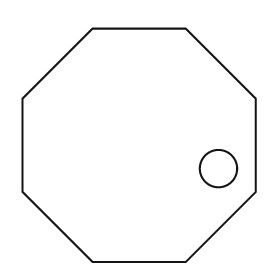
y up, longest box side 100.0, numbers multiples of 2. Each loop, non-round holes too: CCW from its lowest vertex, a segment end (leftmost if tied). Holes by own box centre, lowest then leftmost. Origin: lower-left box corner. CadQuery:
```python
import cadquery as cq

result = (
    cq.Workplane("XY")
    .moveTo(30.0, 0.0)
    .lineTo(70.0, 0.0)
    .lineTo(100.0, 30.0)
    .lineTo(100.0, 70.0)
    .lineTo(70.0, 100.0)
    .lineTo(30.0, 100.0)
    .lineTo(0.0, 70.0)
    .lineTo(0.0, 30.0)
    .close()
    .moveTo(84.0, 40.0)
    .circle(8.0)
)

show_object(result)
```